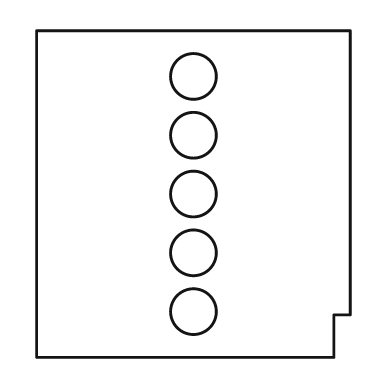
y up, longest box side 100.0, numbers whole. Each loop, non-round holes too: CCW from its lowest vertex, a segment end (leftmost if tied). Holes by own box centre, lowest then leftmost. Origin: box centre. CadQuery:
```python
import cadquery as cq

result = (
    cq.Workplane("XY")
    .moveTo(-48.0, -50.0)
    .lineTo(43.0, -50.0)
    .lineTo(43.0, -37.0)
    .lineTo(48.0, -37.0)
    .lineTo(48.0, 50.0)
    .lineTo(-48.0, 50.0)
    .close()
    .moveTo(0.0, -36.0)
    .circle(7.0)
    .moveTo(0.0, -18.0)
    .circle(7.0)
    .moveTo(0.0, 0.0)
    .circle(7.0)
    .moveTo(0.0, 18.0)
    .circle(7.0)
    .moveTo(0.0, 36.0)
    .circle(7.0)
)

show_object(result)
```